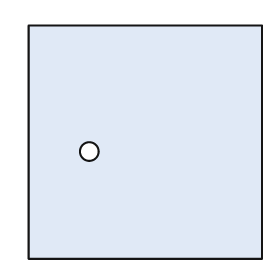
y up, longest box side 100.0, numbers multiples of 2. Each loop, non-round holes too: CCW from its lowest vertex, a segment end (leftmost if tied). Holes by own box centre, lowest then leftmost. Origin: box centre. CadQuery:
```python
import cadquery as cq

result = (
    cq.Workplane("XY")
    .moveTo(-50.0, -50.0)
    .lineTo(50.0, -50.0)
    .lineTo(50.0, 50.0)
    .lineTo(-50.0, 50.0)
    .close()
    .moveTo(-24.0, -4.0)
    .circle(4.0)
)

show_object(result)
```